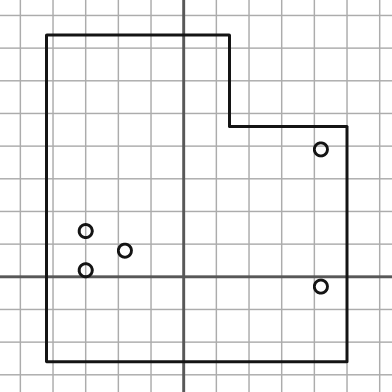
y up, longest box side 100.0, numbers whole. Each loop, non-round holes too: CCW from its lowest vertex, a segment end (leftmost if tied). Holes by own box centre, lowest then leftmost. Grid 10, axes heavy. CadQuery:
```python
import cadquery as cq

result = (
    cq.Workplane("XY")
    .moveTo(-42.0, -26.0)
    .lineTo(50.0, -26.0)
    .lineTo(50.0, 46.0)
    .lineTo(14.0, 46.0)
    .lineTo(14.0, 74.0)
    .lineTo(-42.0, 74.0)
    .close()
    .moveTo(42.0, -3.0)
    .circle(2.0)
    .moveTo(-30.0, 2.0)
    .circle(2.0)
    .moveTo(-18.0, 8.0)
    .circle(2.0)
    .moveTo(-30.0, 14.0)
    .circle(2.0)
    .moveTo(42.0, 39.0)
    .circle(2.0)
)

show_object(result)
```